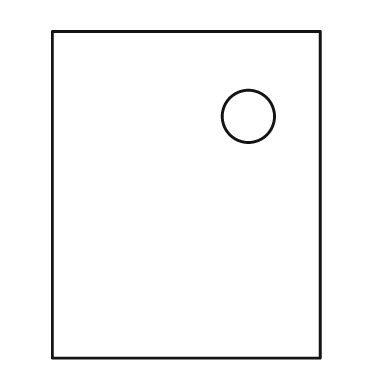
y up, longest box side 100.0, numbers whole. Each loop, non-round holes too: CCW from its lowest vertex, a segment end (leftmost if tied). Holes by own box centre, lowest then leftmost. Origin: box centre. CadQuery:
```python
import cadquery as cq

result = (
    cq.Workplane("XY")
    .moveTo(-41.0, -50.0)
    .lineTo(41.0, -50.0)
    .lineTo(41.0, 50.0)
    .lineTo(-41.0, 50.0)
    .close()
    .moveTo(19.0, 24.0)
    .circle(8.0)
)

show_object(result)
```